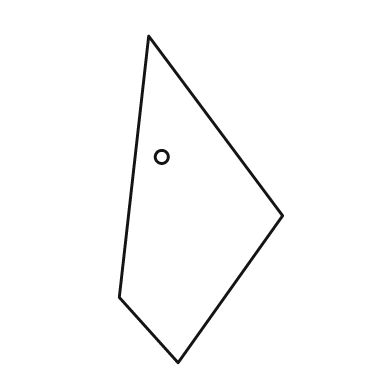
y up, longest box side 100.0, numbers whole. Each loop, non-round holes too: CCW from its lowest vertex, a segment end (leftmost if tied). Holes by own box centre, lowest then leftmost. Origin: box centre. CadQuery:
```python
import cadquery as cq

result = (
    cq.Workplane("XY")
    .moveTo(-7.0, -50.0)
    .lineTo(25.0, -5.0)
    .lineTo(-16.0, 50.0)
    .lineTo(-25.0, -30.0)
    .close()
    .moveTo(-12.0, 13.0)
    .circle(2.0)
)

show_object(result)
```